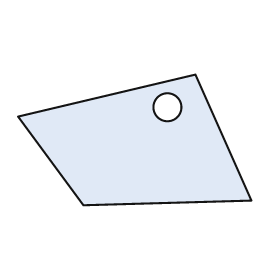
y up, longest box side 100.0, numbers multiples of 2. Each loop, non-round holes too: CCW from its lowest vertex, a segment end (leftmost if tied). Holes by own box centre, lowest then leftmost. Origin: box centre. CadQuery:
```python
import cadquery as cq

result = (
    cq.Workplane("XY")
    .moveTo(-22.0, -28.0)
    .lineTo(50.0, -26.0)
    .lineTo(26.0, 28.0)
    .lineTo(-50.0, 10.0)
    .close()
    .moveTo(14.0, 14.0)
    .circle(6.0)
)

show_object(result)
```